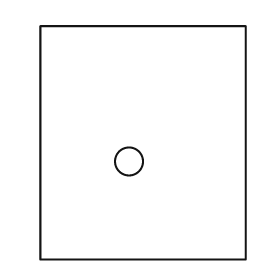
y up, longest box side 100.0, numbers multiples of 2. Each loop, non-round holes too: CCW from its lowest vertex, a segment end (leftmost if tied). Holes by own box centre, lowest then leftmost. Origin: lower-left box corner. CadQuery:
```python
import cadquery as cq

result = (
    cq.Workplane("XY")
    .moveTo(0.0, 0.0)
    .lineTo(88.0, 0.0)
    .lineTo(88.0, 100.0)
    .lineTo(0.0, 100.0)
    .close()
    .moveTo(38.0, 42.0)
    .circle(6.0)
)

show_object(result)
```